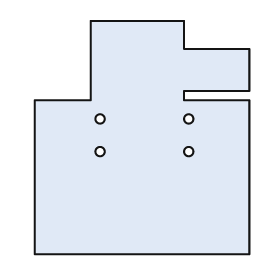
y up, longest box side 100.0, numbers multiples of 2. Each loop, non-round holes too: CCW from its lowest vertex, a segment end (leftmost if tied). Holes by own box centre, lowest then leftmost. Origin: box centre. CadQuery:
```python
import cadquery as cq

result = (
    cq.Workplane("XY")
    .moveTo(-46.0, -50.0)
    .lineTo(46.0, -50.0)
    .lineTo(46.0, 16.0)
    .lineTo(18.0, 16.0)
    .lineTo(18.0, 20.0)
    .lineTo(46.0, 20.0)
    .lineTo(46.0, 38.0)
    .lineTo(18.0, 38.0)
    .lineTo(18.0, 50.0)
    .lineTo(-22.0, 50.0)
    .lineTo(-22.0, 16.0)
    .lineTo(-46.0, 16.0)
    .close()
    .moveTo(-18.0, -6.0)
    .circle(2.0)
    .moveTo(20.0, -6.0)
    .circle(2.0)
    .moveTo(-18.0, 8.0)
    .circle(2.0)
    .moveTo(20.0, 8.0)
    .circle(2.0)
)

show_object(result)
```